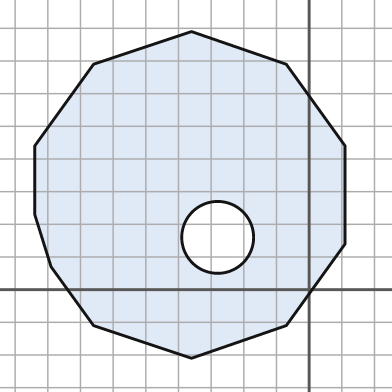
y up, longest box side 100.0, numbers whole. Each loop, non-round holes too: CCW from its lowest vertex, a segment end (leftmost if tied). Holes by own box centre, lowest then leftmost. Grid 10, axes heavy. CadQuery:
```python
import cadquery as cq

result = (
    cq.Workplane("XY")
    .moveTo(-36.0, -21.0)
    .lineTo(-7.0, -11.0)
    .lineTo(11.0, 14.0)
    .lineTo(11.0, 44.0)
    .lineTo(-7.0, 69.0)
    .lineTo(-36.0, 79.0)
    .lineTo(-66.0, 69.0)
    .lineTo(-84.0, 44.0)
    .lineTo(-84.0, 23.0)
    .lineTo(-79.0, 7.0)
    .lineTo(-66.0, -11.0)
    .close()
    .moveTo(-28.0, 16.0)
    .circle(11.0)
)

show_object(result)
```